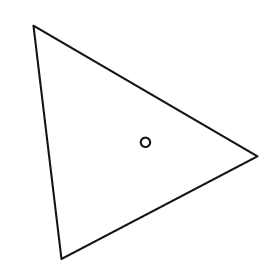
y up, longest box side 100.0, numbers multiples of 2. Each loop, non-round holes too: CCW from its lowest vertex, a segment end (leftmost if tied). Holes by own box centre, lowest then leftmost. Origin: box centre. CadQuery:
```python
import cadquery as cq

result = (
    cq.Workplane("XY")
    .moveTo(-36.0, -50.0)
    .lineTo(48.0, -6.0)
    .lineTo(-48.0, 50.0)
    .close()
    .moveTo(0.0, 0.0)
    .circle(2.0)
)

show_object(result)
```